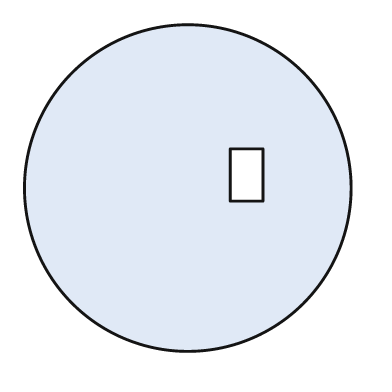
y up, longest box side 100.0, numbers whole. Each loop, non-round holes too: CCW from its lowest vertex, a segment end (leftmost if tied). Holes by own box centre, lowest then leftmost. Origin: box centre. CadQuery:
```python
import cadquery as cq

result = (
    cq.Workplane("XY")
    .moveTo(0.0, 0.0)
    .circle(50.0)
    .moveTo(13.0, -4.0)
    .lineTo(23.0, -4.0)
    .lineTo(23.0, 12.0)
    .lineTo(13.0, 12.0)
    .close()
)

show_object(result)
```